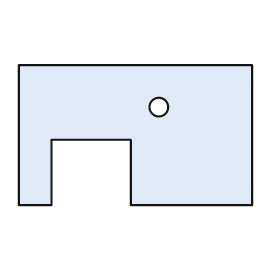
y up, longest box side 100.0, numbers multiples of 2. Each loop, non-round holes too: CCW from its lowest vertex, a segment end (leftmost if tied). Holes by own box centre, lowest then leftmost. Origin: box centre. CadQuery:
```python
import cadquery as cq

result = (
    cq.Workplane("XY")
    .moveTo(-50.0, -30.0)
    .lineTo(-36.0, -30.0)
    .lineTo(-36.0, -2.0)
    .lineTo(-2.0, -2.0)
    .lineTo(-2.0, -30.0)
    .lineTo(50.0, -30.0)
    .lineTo(50.0, 30.0)
    .lineTo(-50.0, 30.0)
    .close()
    .moveTo(10.0, 12.0)
    .circle(4.0)
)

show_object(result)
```